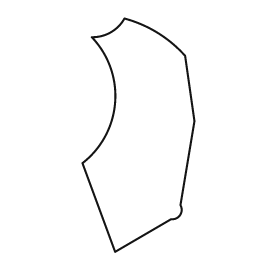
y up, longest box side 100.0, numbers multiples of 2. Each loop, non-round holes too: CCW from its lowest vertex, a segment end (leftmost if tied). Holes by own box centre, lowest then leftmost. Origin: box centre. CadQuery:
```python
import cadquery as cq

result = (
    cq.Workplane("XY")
    .moveTo(-10.0, -50.0)
    .lineTo(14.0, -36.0)
    .threePointArc((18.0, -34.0), (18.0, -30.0))
    .lineTo(24.0, 6.0)
    .lineTo(20.0, 34.0)
    .threePointArc((8.0, 44.0), (-6.0, 50.0))
    .threePointArc((-12.0, 44.0), (-20.0, 42.0))
    .threePointArc((-10.0, 14.0), (-24.0, -12.0))
    .close()
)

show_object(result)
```